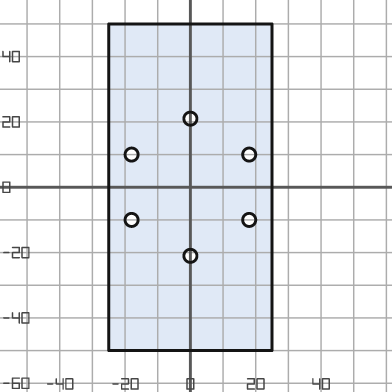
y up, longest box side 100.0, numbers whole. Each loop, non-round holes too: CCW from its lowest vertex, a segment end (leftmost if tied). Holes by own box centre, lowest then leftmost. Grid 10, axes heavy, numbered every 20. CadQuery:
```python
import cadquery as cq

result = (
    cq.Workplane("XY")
    .moveTo(-25.0, -50.0)
    .lineTo(25.0, -50.0)
    .lineTo(25.0, 50.0)
    .lineTo(-25.0, 50.0)
    .close()
    .moveTo(0.0, -21.0)
    .circle(2.0)
    .moveTo(-18.0, -10.0)
    .circle(2.0)
    .moveTo(18.0, -10.0)
    .circle(2.0)
    .moveTo(-18.0, 10.0)
    .circle(2.0)
    .moveTo(18.0, 10.0)
    .circle(2.0)
    .moveTo(0.0, 21.0)
    .circle(2.0)
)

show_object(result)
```